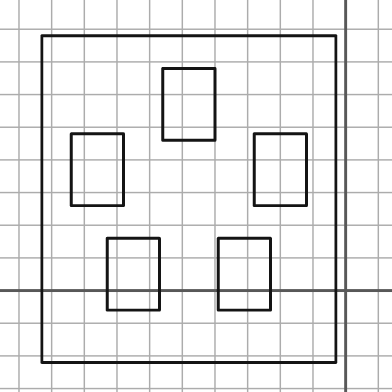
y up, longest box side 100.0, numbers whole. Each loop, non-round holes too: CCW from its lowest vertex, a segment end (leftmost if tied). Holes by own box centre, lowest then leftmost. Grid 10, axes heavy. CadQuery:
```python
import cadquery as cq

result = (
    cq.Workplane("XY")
    .moveTo(-93.0, -22.0)
    .lineTo(-3.0, -22.0)
    .lineTo(-3.0, 78.0)
    .lineTo(-93.0, 78.0)
    .close()
    .moveTo(-73.0, -6.0)
    .lineTo(-57.0, -6.0)
    .lineTo(-57.0, 16.0)
    .lineTo(-73.0, 16.0)
    .close()
    .moveTo(-39.0, -6.0)
    .lineTo(-23.0, -6.0)
    .lineTo(-23.0, 16.0)
    .lineTo(-39.0, 16.0)
    .close()
    .moveTo(-84.0, 26.0)
    .lineTo(-68.0, 26.0)
    .lineTo(-68.0, 48.0)
    .lineTo(-84.0, 48.0)
    .close()
    .moveTo(-28.0, 26.0)
    .lineTo(-12.0, 26.0)
    .lineTo(-12.0, 48.0)
    .lineTo(-28.0, 48.0)
    .close()
    .moveTo(-56.0, 46.0)
    .lineTo(-40.0, 46.0)
    .lineTo(-40.0, 68.0)
    .lineTo(-56.0, 68.0)
    .close()
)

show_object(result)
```